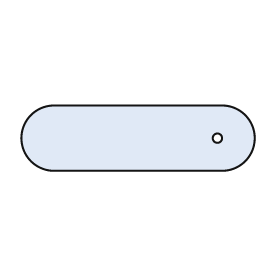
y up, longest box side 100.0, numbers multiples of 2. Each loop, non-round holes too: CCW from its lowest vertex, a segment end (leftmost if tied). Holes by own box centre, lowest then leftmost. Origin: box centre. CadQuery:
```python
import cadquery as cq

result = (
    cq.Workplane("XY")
    .moveTo(-36.0, -14.0)
    .lineTo(36.0, -14.0)
    .threePointArc((50.0, 0.0), (36.0, 14.0))
    .lineTo(-36.0, 14.0)
    .threePointArc((-50.0, 0.0), (-36.0, -14.0))
    .close()
    .moveTo(34.0, 0.0)
    .circle(2.0)
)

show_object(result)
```